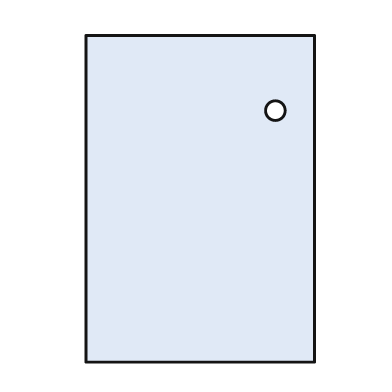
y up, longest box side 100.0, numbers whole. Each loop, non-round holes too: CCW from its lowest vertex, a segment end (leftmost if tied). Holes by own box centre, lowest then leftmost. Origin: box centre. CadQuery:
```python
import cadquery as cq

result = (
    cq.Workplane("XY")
    .moveTo(-35.0, -50.0)
    .lineTo(35.0, -50.0)
    .lineTo(35.0, 50.0)
    .lineTo(-35.0, 50.0)
    .close()
    .moveTo(23.0, 27.0)
    .circle(3.0)
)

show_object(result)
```